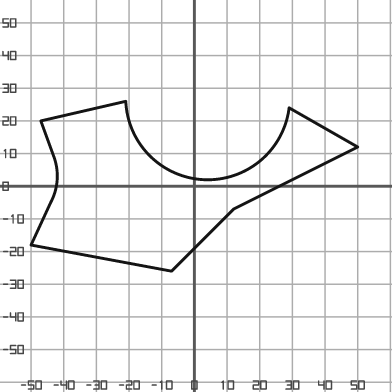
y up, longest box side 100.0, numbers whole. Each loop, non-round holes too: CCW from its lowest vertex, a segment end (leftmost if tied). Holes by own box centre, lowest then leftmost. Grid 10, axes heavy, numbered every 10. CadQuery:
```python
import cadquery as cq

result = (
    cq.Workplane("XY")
    .moveTo(-7.0, -26.0)
    .lineTo(12.0, -7.0)
    .lineTo(50.0, 12.0)
    .lineTo(29.0, 24.0)
    .threePointArc((3.0, 2.0), (-21.0, 26.0))
    .lineTo(-47.0, 20.0)
    .lineTo(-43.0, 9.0)
    .threePointArc((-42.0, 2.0), (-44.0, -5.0))
    .lineTo(-50.0, -18.0)
    .close()
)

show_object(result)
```